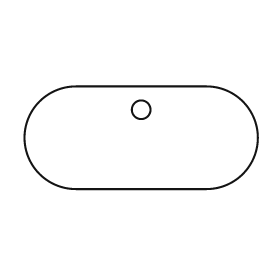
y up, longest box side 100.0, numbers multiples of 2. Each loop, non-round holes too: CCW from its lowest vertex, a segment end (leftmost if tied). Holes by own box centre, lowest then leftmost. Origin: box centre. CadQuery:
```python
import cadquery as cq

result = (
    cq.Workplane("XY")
    .moveTo(-28.0, -22.0)
    .lineTo(28.0, -22.0)
    .threePointArc((50.0, 0.0), (28.0, 22.0))
    .lineTo(-28.0, 22.0)
    .threePointArc((-50.0, 0.0), (-28.0, -22.0))
    .close()
    .moveTo(0.0, 12.0)
    .circle(4.0)
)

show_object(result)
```